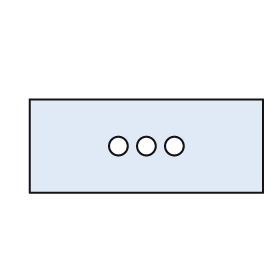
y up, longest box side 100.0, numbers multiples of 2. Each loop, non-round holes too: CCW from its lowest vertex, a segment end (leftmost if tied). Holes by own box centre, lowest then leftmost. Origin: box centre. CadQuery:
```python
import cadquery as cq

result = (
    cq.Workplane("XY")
    .moveTo(-50.0, -20.0)
    .lineTo(50.0, -20.0)
    .lineTo(50.0, 20.0)
    .lineTo(-50.0, 20.0)
    .close()
    .moveTo(-12.0, 0.0)
    .circle(4.0)
    .moveTo(0.0, 0.0)
    .circle(4.0)
    .moveTo(12.0, 0.0)
    .circle(4.0)
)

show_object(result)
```